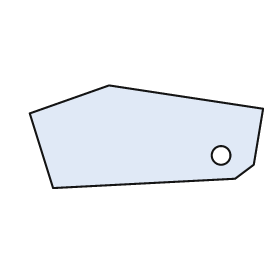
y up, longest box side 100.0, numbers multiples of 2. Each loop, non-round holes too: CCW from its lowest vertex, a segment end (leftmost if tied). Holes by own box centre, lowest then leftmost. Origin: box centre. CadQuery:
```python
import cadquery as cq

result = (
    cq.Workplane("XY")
    .moveTo(-40.0, -22.0)
    .lineTo(38.0, -18.0)
    .lineTo(46.0, -12.0)
    .lineTo(50.0, 12.0)
    .lineTo(-16.0, 22.0)
    .lineTo(-50.0, 10.0)
    .close()
    .moveTo(32.0, -8.0)
    .circle(4.0)
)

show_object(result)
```